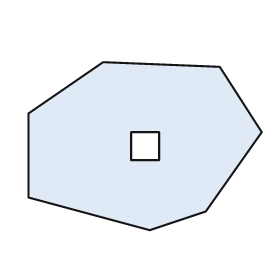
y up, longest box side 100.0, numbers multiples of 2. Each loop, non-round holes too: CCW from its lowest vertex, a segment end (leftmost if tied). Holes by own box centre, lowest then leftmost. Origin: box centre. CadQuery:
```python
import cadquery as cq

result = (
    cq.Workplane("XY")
    .moveTo(2.0, -36.0)
    .lineTo(26.0, -28.0)
    .lineTo(50.0, 6.0)
    .lineTo(32.0, 34.0)
    .lineTo(-18.0, 36.0)
    .lineTo(-50.0, 14.0)
    .lineTo(-50.0, -22.0)
    .close()
    .moveTo(-6.0, -6.0)
    .lineTo(6.0, -6.0)
    .lineTo(6.0, 6.0)
    .lineTo(-6.0, 6.0)
    .close()
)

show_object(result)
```